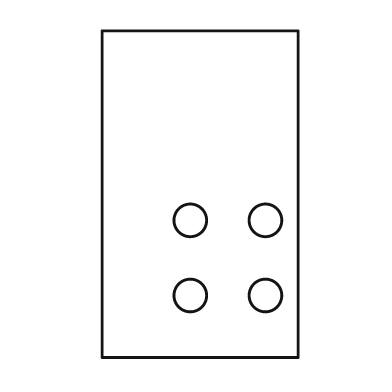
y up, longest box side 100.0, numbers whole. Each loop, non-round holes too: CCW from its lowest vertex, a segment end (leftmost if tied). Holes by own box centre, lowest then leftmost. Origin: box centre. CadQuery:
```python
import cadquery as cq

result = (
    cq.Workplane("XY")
    .moveTo(-30.0, -50.0)
    .lineTo(30.0, -50.0)
    .lineTo(30.0, 50.0)
    .lineTo(-30.0, 50.0)
    .close()
    .moveTo(-3.0, -31.0)
    .circle(5.0)
    .moveTo(20.0, -31.0)
    .circle(5.0)
    .moveTo(-3.0, -8.0)
    .circle(5.0)
    .moveTo(20.0, -8.0)
    .circle(5.0)
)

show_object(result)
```